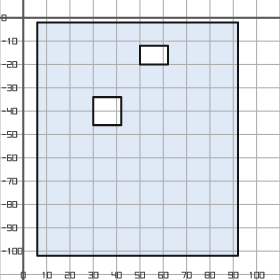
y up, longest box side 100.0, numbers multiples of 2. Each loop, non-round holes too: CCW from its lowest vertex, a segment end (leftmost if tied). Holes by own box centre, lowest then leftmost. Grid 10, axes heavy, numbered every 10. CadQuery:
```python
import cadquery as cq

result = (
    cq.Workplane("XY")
    .moveTo(6.0, -102.0)
    .lineTo(92.0, -102.0)
    .lineTo(92.0, -2.0)
    .lineTo(6.0, -2.0)
    .close()
    .moveTo(30.0, -46.0)
    .lineTo(42.0, -46.0)
    .lineTo(42.0, -34.0)
    .lineTo(30.0, -34.0)
    .close()
    .moveTo(50.0, -20.0)
    .lineTo(62.0, -20.0)
    .lineTo(62.0, -12.0)
    .lineTo(50.0, -12.0)
    .close()
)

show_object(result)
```